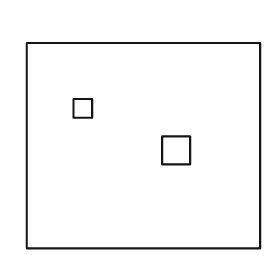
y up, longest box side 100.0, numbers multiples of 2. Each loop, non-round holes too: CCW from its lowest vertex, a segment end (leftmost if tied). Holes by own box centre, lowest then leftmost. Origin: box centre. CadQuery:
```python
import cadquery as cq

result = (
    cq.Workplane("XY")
    .moveTo(-50.0, -44.0)
    .lineTo(50.0, -44.0)
    .lineTo(50.0, 44.0)
    .lineTo(-50.0, 44.0)
    .close()
    .moveTo(8.0, -8.0)
    .lineTo(20.0, -8.0)
    .lineTo(20.0, 4.0)
    .lineTo(8.0, 4.0)
    .close()
    .moveTo(-30.0, 12.0)
    .lineTo(-22.0, 12.0)
    .lineTo(-22.0, 20.0)
    .lineTo(-30.0, 20.0)
    .close()
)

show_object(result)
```